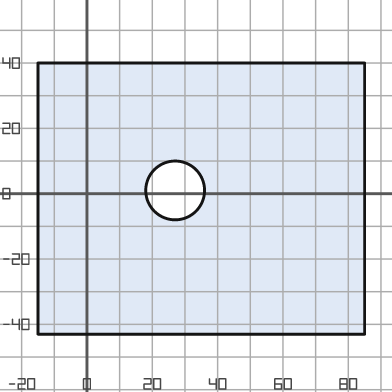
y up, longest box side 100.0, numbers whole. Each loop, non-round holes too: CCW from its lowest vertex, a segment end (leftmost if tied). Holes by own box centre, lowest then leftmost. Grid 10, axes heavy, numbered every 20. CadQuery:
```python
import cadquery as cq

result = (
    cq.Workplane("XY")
    .moveTo(-15.0, -43.0)
    .lineTo(85.0, -43.0)
    .lineTo(85.0, 40.0)
    .lineTo(-15.0, 40.0)
    .close()
    .moveTo(27.0, 1.0)
    .circle(9.0)
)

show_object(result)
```